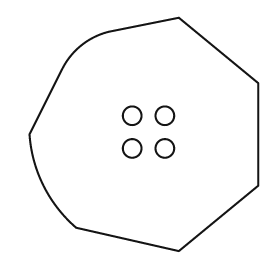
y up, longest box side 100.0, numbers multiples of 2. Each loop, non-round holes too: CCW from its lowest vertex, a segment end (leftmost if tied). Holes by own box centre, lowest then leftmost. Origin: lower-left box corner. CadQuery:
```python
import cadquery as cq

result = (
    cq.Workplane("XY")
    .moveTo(64.0, 0.0)
    .lineTo(98.0, 28.0)
    .lineTo(98.0, 72.0)
    .lineTo(64.0, 100.0)
    .lineTo(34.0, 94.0)
    .threePointArc((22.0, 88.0), (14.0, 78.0))
    .lineTo(0.0, 50.0)
    .threePointArc((6.0, 28.0), (20.0, 10.0))
    .close()
    .moveTo(44.0, 44.0)
    .circle(4.0)
    .moveTo(58.0, 44.0)
    .circle(4.0)
    .moveTo(44.0, 58.0)
    .circle(4.0)
    .moveTo(58.0, 58.0)
    .circle(4.0)
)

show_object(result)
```